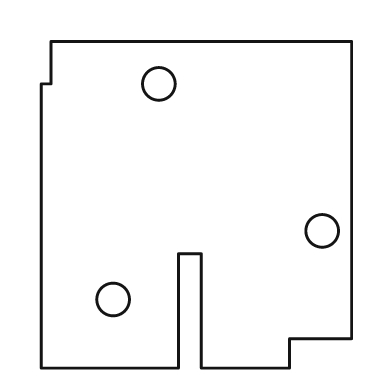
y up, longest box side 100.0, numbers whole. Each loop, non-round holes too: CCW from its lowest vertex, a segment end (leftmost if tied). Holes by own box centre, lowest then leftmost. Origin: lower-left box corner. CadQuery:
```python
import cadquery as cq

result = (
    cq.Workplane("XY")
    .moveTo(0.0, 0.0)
    .lineTo(42.0, 0.0)
    .lineTo(42.0, 35.0)
    .lineTo(49.0, 35.0)
    .lineTo(49.0, 0.0)
    .lineTo(76.0, 0.0)
    .lineTo(76.0, 9.0)
    .lineTo(95.0, 9.0)
    .lineTo(95.0, 100.0)
    .lineTo(3.0, 100.0)
    .lineTo(3.0, 87.0)
    .lineTo(0.0, 87.0)
    .close()
    .moveTo(22.0, 21.0)
    .circle(5.0)
    .moveTo(86.0, 42.0)
    .circle(5.0)
    .moveTo(36.0, 87.0)
    .circle(5.0)
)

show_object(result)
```